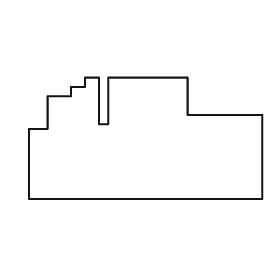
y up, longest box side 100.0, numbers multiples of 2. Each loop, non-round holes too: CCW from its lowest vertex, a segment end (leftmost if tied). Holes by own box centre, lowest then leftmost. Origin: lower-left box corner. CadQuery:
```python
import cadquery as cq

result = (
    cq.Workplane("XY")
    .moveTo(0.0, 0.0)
    .lineTo(100.0, 0.0)
    .lineTo(100.0, 36.0)
    .lineTo(68.0, 36.0)
    .lineTo(68.0, 52.0)
    .lineTo(34.0, 52.0)
    .lineTo(34.0, 32.0)
    .lineTo(30.0, 32.0)
    .lineTo(30.0, 52.0)
    .lineTo(24.0, 52.0)
    .lineTo(24.0, 48.0)
    .lineTo(18.0, 48.0)
    .lineTo(18.0, 44.0)
    .lineTo(8.0, 44.0)
    .lineTo(8.0, 30.0)
    .lineTo(0.0, 30.0)
    .close()
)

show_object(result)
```